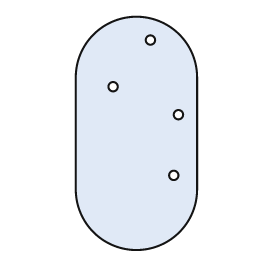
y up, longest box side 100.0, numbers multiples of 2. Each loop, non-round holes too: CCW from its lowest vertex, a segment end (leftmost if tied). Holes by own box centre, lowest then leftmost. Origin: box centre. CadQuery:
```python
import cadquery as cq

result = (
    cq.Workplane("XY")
    .moveTo(-26.0, -24.0)
    .threePointArc((0.0, -50.0), (26.0, -24.0))
    .lineTo(26.0, 24.0)
    .threePointArc((0.0, 50.0), (-26.0, 24.0))
    .close()
    .moveTo(16.0, -18.0)
    .circle(2.0)
    .moveTo(18.0, 8.0)
    .circle(2.0)
    .moveTo(-10.0, 20.0)
    .circle(2.0)
    .moveTo(6.0, 40.0)
    .circle(2.0)
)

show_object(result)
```